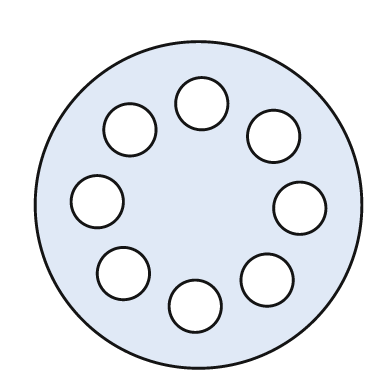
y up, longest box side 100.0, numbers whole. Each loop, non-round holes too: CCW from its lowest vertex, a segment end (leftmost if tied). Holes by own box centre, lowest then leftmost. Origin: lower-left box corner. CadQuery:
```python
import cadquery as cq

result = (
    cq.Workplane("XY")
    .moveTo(50.0, 50.0)
    .circle(50.0)
    .moveTo(49.0, 19.0)
    .circle(8.0)
    .moveTo(71.0, 27.0)
    .circle(8.0)
    .moveTo(27.0, 29.0)
    .circle(8.0)
    .moveTo(81.0, 49.0)
    .circle(8.0)
    .moveTo(19.0, 51.0)
    .circle(8.0)
    .moveTo(73.0, 71.0)
    .circle(8.0)
    .moveTo(29.0, 73.0)
    .circle(8.0)
    .moveTo(51.0, 81.0)
    .circle(8.0)
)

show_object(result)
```